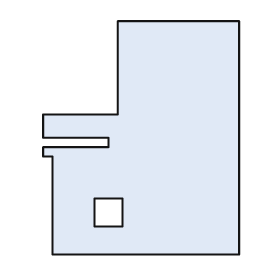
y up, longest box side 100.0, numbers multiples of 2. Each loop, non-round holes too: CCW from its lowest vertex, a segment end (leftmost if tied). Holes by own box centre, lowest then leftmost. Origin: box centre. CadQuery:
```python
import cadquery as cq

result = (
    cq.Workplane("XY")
    .moveTo(-38.0, -50.0)
    .lineTo(42.0, -50.0)
    .lineTo(42.0, 50.0)
    .lineTo(-10.0, 50.0)
    .lineTo(-10.0, 10.0)
    .lineTo(-42.0, 10.0)
    .lineTo(-42.0, 0.0)
    .lineTo(-14.0, 0.0)
    .lineTo(-14.0, -4.0)
    .lineTo(-42.0, -4.0)
    .lineTo(-42.0, -8.0)
    .lineTo(-38.0, -8.0)
    .close()
    .moveTo(-20.0, -38.0)
    .lineTo(-8.0, -38.0)
    .lineTo(-8.0, -26.0)
    .lineTo(-20.0, -26.0)
    .close()
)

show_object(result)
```